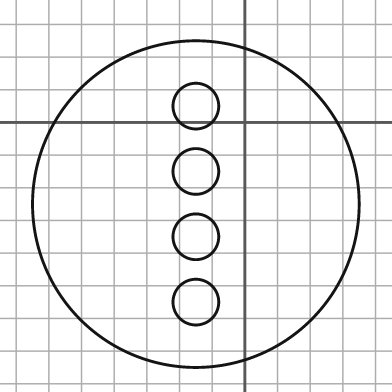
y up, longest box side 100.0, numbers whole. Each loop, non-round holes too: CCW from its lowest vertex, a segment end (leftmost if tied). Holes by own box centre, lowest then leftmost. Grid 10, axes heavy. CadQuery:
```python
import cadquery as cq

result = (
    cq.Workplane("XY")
    .moveTo(-15.0, -25.0)
    .circle(50.0)
    .moveTo(-15.0, -55.0)
    .circle(7.0)
    .moveTo(-15.0, -35.0)
    .circle(7.0)
    .moveTo(-15.0, -15.0)
    .circle(7.0)
    .moveTo(-15.0, 5.0)
    .circle(7.0)
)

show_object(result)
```